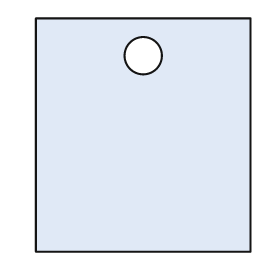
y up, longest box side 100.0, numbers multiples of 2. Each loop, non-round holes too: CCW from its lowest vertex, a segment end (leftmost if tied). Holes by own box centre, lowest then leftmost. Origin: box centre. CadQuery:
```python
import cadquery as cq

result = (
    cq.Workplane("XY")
    .moveTo(-46.0, -50.0)
    .lineTo(46.0, -50.0)
    .lineTo(46.0, 50.0)
    .lineTo(-46.0, 50.0)
    .close()
    .moveTo(0.0, 34.0)
    .circle(8.0)
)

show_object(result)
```